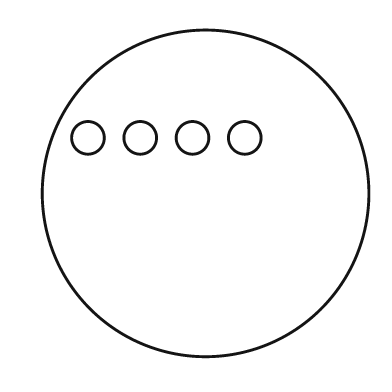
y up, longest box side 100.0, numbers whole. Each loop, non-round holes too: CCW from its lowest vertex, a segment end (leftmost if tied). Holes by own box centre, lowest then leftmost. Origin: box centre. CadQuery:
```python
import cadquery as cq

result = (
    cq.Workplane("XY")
    .moveTo(0.0, 0.0)
    .circle(50.0)
    .moveTo(-36.0, 17.0)
    .circle(5.0)
    .moveTo(-20.0, 17.0)
    .circle(5.0)
    .moveTo(-4.0, 17.0)
    .circle(5.0)
    .moveTo(12.0, 17.0)
    .circle(5.0)
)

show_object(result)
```